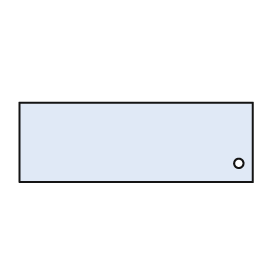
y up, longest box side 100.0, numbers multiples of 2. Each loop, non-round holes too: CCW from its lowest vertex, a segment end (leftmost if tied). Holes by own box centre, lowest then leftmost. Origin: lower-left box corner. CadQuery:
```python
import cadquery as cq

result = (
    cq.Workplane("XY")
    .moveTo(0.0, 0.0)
    .lineTo(100.0, 0.0)
    .lineTo(100.0, 34.0)
    .lineTo(0.0, 34.0)
    .close()
    .moveTo(94.0, 8.0)
    .circle(2.0)
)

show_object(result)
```